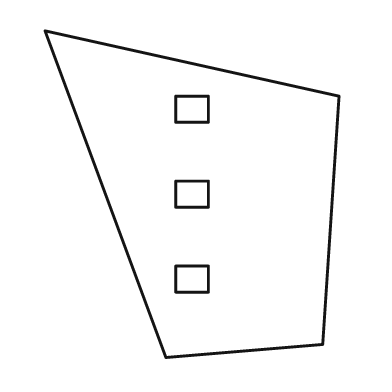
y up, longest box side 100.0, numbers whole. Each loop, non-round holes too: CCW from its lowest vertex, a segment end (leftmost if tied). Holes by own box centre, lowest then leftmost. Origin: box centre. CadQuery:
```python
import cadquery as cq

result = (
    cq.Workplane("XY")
    .moveTo(-8.0, -50.0)
    .lineTo(40.0, -46.0)
    .lineTo(45.0, 30.0)
    .lineTo(-45.0, 50.0)
    .close()
    .moveTo(-5.0, -30.0)
    .lineTo(5.0, -30.0)
    .lineTo(5.0, -22.0)
    .lineTo(-5.0, -22.0)
    .close()
    .moveTo(-5.0, -4.0)
    .lineTo(5.0, -4.0)
    .lineTo(5.0, 4.0)
    .lineTo(-5.0, 4.0)
    .close()
    .moveTo(-5.0, 22.0)
    .lineTo(5.0, 22.0)
    .lineTo(5.0, 30.0)
    .lineTo(-5.0, 30.0)
    .close()
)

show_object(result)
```